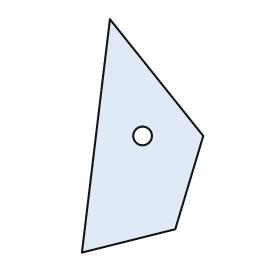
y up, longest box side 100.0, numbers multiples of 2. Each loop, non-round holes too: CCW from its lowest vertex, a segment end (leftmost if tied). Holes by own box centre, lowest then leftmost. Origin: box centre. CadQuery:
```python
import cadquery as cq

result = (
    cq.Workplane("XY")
    .moveTo(-26.0, -50.0)
    .lineTo(14.0, -40.0)
    .lineTo(26.0, 0.0)
    .lineTo(-14.0, 50.0)
    .close()
    .moveTo(0.0, 0.0)
    .circle(4.0)
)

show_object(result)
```